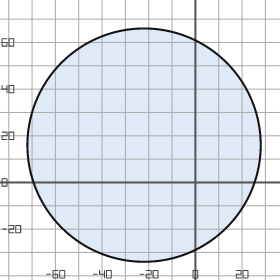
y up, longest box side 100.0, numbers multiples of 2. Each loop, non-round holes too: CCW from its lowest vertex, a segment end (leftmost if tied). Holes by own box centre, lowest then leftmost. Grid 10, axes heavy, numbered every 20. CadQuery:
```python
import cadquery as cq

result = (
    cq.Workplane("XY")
    .moveTo(-22.0, 16.0)
    .circle(50.0)
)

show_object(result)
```